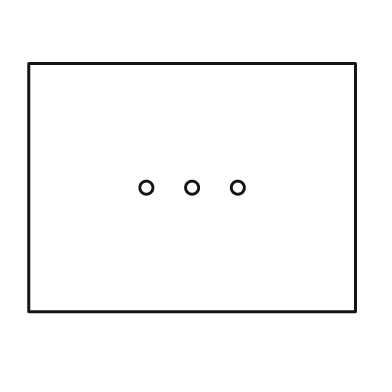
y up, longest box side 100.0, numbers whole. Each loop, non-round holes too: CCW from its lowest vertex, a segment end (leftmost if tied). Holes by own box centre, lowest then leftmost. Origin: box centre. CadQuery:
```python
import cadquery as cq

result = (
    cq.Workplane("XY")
    .moveTo(-50.0, -38.0)
    .lineTo(50.0, -38.0)
    .lineTo(50.0, 38.0)
    .lineTo(-50.0, 38.0)
    .close()
    .moveTo(-14.0, 0.0)
    .circle(2.0)
    .moveTo(0.0, 0.0)
    .circle(2.0)
    .moveTo(14.0, 0.0)
    .circle(2.0)
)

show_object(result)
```